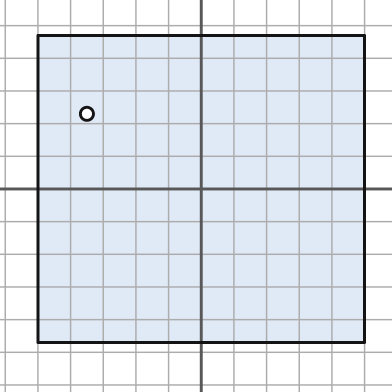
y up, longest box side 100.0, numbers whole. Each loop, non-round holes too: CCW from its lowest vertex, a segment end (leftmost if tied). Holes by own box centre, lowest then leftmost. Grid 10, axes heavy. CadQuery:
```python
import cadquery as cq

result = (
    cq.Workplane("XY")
    .moveTo(-50.0, -47.0)
    .lineTo(50.0, -47.0)
    .lineTo(50.0, 47.0)
    .lineTo(-50.0, 47.0)
    .close()
    .moveTo(-35.0, 23.0)
    .circle(2.0)
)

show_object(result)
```